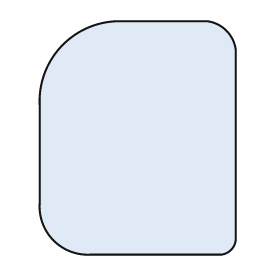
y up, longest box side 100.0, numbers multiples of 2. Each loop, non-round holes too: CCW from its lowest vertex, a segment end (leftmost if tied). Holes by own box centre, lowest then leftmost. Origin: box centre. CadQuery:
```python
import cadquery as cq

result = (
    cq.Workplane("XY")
    .moveTo(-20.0, -50.0)
    .lineTo(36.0, -50.0)
    .threePointArc((40.0, -48.0), (42.0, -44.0))
    .lineTo(42.0, 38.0)
    .threePointArc((38.0, 46.0), (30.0, 50.0))
    .lineTo(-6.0, 50.0)
    .threePointArc((-32.0, 40.0), (-42.0, 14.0))
    .lineTo(-42.0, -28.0)
    .threePointArc((-36.0, -44.0), (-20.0, -50.0))
    .close()
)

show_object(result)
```